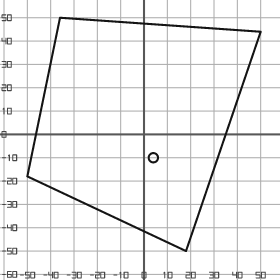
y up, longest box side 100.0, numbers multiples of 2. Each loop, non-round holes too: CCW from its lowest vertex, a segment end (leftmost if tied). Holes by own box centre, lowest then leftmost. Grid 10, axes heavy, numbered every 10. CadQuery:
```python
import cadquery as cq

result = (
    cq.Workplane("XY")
    .moveTo(18.0, -50.0)
    .lineTo(50.0, 44.0)
    .lineTo(-36.0, 50.0)
    .lineTo(-50.0, -18.0)
    .close()
    .moveTo(4.0, -10.0)
    .circle(2.0)
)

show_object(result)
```